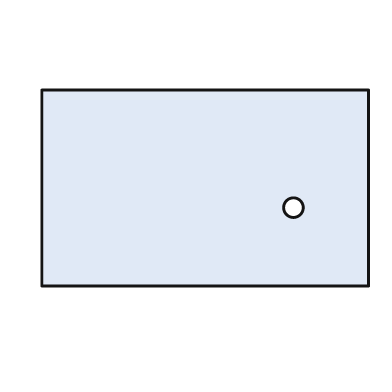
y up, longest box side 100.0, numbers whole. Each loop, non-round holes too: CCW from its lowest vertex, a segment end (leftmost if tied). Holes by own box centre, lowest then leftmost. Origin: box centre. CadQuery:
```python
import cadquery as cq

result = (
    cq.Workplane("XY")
    .moveTo(-50.0, -30.0)
    .lineTo(50.0, -30.0)
    .lineTo(50.0, 30.0)
    .lineTo(-50.0, 30.0)
    .close()
    .moveTo(27.0, -6.0)
    .circle(3.0)
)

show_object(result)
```